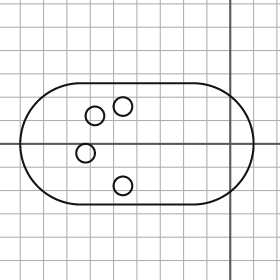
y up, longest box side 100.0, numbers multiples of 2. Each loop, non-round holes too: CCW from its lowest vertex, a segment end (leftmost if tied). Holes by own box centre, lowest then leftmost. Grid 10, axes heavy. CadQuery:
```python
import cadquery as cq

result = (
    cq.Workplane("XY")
    .moveTo(-64.0, -26.0)
    .lineTo(-16.0, -26.0)
    .threePointArc((10.0, 0.0), (-16.0, 26.0))
    .lineTo(-64.0, 26.0)
    .threePointArc((-90.0, 0.0), (-64.0, -26.0))
    .close()
    .moveTo(-46.0, -18.0)
    .circle(4.0)
    .moveTo(-62.0, -4.0)
    .circle(4.0)
    .moveTo(-58.0, 12.0)
    .circle(4.0)
    .moveTo(-46.0, 16.0)
    .circle(4.0)
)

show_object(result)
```